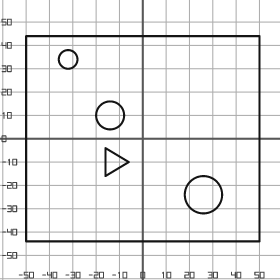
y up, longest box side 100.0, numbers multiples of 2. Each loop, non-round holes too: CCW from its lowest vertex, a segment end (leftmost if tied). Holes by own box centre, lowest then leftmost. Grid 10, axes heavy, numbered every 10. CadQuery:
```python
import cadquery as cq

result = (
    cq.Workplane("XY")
    .moveTo(-50.0, -44.0)
    .lineTo(50.0, -44.0)
    .lineTo(50.0, 44.0)
    .lineTo(-50.0, 44.0)
    .close()
    .moveTo(26.0, -24.0)
    .circle(8.0)
    .moveTo(-16.0, -16.0)
    .lineTo(-6.0, -10.0)
    .lineTo(-16.0, -4.0)
    .close()
    .moveTo(-14.0, 10.0)
    .circle(6.0)
    .moveTo(-32.0, 34.0)
    .circle(4.0)
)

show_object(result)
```